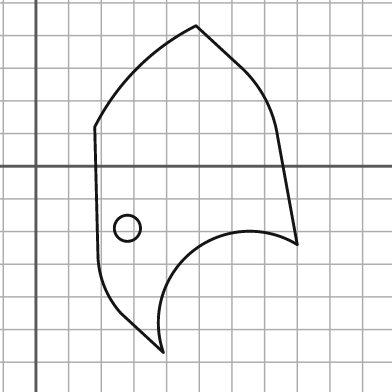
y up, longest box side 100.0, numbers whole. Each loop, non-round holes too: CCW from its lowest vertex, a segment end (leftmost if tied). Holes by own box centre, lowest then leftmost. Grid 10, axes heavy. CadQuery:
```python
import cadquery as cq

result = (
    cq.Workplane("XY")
    .moveTo(39.0, -57.0)
    .threePointArc((48.0, -26.0), (80.0, -24.0))
    .lineTo(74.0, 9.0)
    .threePointArc((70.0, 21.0), (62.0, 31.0))
    .lineTo(49.0, 43.0)
    .threePointArc((31.0, 30.0), (18.0, 12.0))
    .lineTo(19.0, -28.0)
    .threePointArc((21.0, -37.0), (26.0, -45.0))
    .close()
    .moveTo(28.0, -19.0)
    .circle(4.0)
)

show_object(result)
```